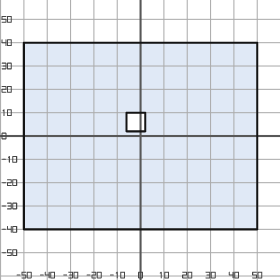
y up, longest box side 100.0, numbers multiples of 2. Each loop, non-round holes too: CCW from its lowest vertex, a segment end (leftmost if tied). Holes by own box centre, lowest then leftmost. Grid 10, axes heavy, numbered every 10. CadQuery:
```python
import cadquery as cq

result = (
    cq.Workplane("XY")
    .moveTo(-50.0, -40.0)
    .lineTo(50.0, -40.0)
    .lineTo(50.0, 40.0)
    .lineTo(-50.0, 40.0)
    .close()
    .moveTo(-6.0, 2.0)
    .lineTo(2.0, 2.0)
    .lineTo(2.0, 10.0)
    .lineTo(-6.0, 10.0)
    .close()
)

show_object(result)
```